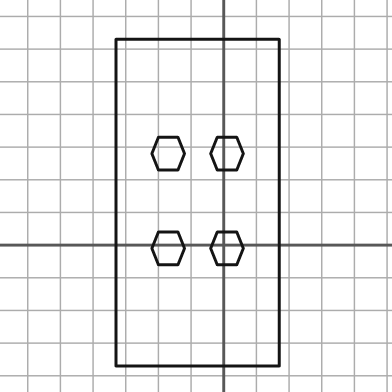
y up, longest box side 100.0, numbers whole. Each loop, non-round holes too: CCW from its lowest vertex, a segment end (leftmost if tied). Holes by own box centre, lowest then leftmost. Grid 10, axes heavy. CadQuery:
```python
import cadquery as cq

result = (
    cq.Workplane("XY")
    .moveTo(-33.0, -37.0)
    .lineTo(17.0, -37.0)
    .lineTo(17.0, 63.0)
    .lineTo(-33.0, 63.0)
    .close()
    .moveTo(-20.0, -6.0)
    .lineTo(-14.0, -6.0)
    .lineTo(-12.0, -1.0)
    .lineTo(-14.0, 4.0)
    .lineTo(-20.0, 4.0)
    .lineTo(-22.0, -1.0)
    .close()
    .moveTo(-2.0, -6.0)
    .lineTo(4.0, -6.0)
    .lineTo(6.0, -1.0)
    .lineTo(4.0, 4.0)
    .lineTo(-2.0, 4.0)
    .lineTo(-4.0, -1.0)
    .close()
    .moveTo(-20.0, 23.0)
    .lineTo(-14.0, 23.0)
    .lineTo(-12.0, 28.0)
    .lineTo(-14.0, 33.0)
    .lineTo(-20.0, 33.0)
    .lineTo(-22.0, 28.0)
    .close()
    .moveTo(-2.0, 23.0)
    .lineTo(4.0, 23.0)
    .lineTo(6.0, 28.0)
    .lineTo(4.0, 33.0)
    .lineTo(-2.0, 33.0)
    .lineTo(-4.0, 28.0)
    .close()
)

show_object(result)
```